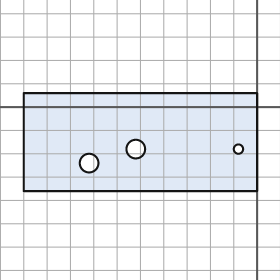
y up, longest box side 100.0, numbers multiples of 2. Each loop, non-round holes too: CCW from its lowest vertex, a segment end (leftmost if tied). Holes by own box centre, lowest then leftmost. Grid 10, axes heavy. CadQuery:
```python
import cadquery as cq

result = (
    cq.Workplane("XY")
    .moveTo(-100.0, -36.0)
    .lineTo(0.0, -36.0)
    .lineTo(0.0, 6.0)
    .lineTo(-100.0, 6.0)
    .close()
    .moveTo(-72.0, -24.0)
    .circle(4.0)
    .moveTo(-52.0, -18.0)
    .circle(4.0)
    .moveTo(-8.0, -18.0)
    .circle(2.0)
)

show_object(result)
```